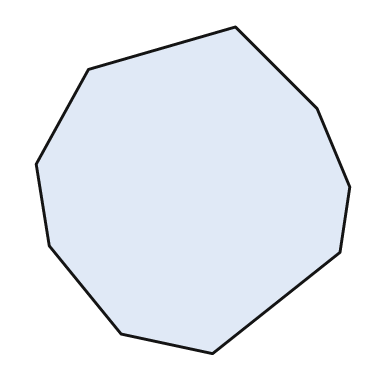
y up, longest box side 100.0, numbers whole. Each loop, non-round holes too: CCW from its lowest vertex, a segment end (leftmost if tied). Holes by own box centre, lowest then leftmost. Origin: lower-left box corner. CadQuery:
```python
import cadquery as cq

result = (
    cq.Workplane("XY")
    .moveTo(54.0, 0.0)
    .lineTo(93.0, 31.0)
    .lineTo(96.0, 51.0)
    .lineTo(86.0, 75.0)
    .lineTo(61.0, 100.0)
    .lineTo(16.0, 87.0)
    .lineTo(0.0, 58.0)
    .lineTo(4.0, 33.0)
    .lineTo(26.0, 6.0)
    .close()
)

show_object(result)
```